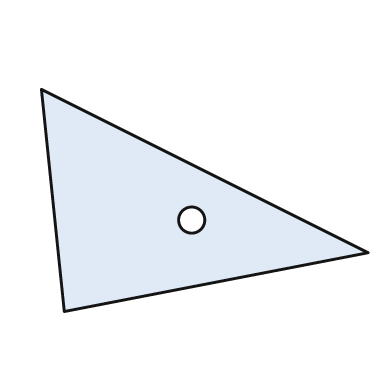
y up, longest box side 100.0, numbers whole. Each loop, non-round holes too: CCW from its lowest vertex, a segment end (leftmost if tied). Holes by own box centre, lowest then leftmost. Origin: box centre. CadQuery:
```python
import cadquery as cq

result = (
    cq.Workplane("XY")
    .moveTo(-43.0, -34.0)
    .lineTo(50.0, -16.0)
    .lineTo(-50.0, 34.0)
    .close()
    .moveTo(-4.0, -6.0)
    .circle(4.0)
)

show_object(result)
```